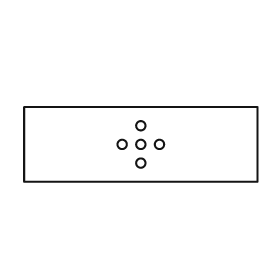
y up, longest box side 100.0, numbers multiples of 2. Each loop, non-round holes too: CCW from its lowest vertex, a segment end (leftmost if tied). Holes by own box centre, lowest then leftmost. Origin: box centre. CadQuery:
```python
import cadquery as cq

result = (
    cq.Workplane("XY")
    .moveTo(-50.0, -16.0)
    .lineTo(50.0, -16.0)
    .lineTo(50.0, 16.0)
    .lineTo(-50.0, 16.0)
    .close()
    .moveTo(0.0, -8.0)
    .circle(2.0)
    .moveTo(-8.0, 0.0)
    .circle(2.0)
    .moveTo(0.0, 0.0)
    .circle(2.0)
    .moveTo(8.0, 0.0)
    .circle(2.0)
    .moveTo(0.0, 8.0)
    .circle(2.0)
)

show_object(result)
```